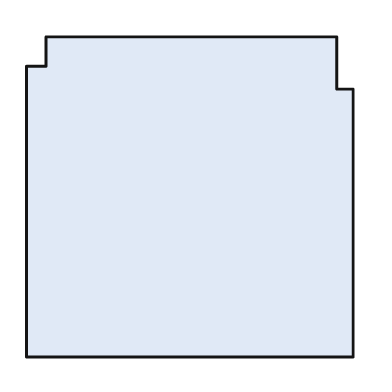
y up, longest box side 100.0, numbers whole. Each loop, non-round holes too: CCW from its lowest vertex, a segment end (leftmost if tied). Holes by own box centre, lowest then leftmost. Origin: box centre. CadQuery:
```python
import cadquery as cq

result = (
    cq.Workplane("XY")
    .moveTo(-50.0, -49.0)
    .lineTo(50.0, -49.0)
    .lineTo(50.0, 33.0)
    .lineTo(45.0, 33.0)
    .lineTo(45.0, 49.0)
    .lineTo(-44.0, 49.0)
    .lineTo(-44.0, 40.0)
    .lineTo(-50.0, 40.0)
    .close()
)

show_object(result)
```